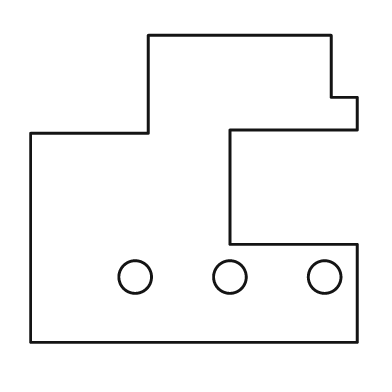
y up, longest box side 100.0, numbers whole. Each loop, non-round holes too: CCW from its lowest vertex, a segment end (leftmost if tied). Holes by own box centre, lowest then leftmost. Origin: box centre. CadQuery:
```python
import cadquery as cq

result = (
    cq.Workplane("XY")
    .moveTo(-50.0, -47.0)
    .lineTo(50.0, -47.0)
    .lineTo(50.0, -17.0)
    .lineTo(11.0, -17.0)
    .lineTo(11.0, 18.0)
    .lineTo(50.0, 18.0)
    .lineTo(50.0, 28.0)
    .lineTo(42.0, 28.0)
    .lineTo(42.0, 47.0)
    .lineTo(-14.0, 47.0)
    .lineTo(-14.0, 17.0)
    .lineTo(-50.0, 17.0)
    .close()
    .moveTo(-18.0, -27.0)
    .circle(5.0)
    .moveTo(11.0, -27.0)
    .circle(5.0)
    .moveTo(40.0, -27.0)
    .circle(5.0)
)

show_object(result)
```